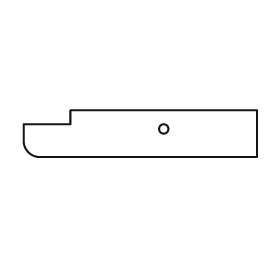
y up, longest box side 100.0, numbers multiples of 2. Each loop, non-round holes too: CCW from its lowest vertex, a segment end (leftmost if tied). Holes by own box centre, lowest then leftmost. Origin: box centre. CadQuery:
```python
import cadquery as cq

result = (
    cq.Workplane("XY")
    .moveTo(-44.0, -10.0)
    .lineTo(50.0, -10.0)
    .lineTo(50.0, 10.0)
    .lineTo(-30.0, 10.0)
    .lineTo(-30.0, 4.0)
    .lineTo(-50.0, 4.0)
    .lineTo(-50.0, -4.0)
    .threePointArc((-48.0, -8.0), (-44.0, -10.0))
    .close()
    .moveTo(10.0, 2.0)
    .circle(2.0)
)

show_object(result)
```